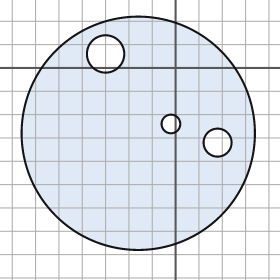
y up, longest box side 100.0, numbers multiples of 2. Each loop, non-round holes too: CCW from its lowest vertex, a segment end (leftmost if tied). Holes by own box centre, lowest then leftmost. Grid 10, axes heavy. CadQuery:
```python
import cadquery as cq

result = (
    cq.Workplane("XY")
    .moveTo(-16.0, -28.0)
    .circle(50.0)
    .moveTo(18.0, -32.0)
    .circle(6.0)
    .moveTo(-2.0, -24.0)
    .circle(4.0)
    .moveTo(-30.0, 6.0)
    .circle(8.0)
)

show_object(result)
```